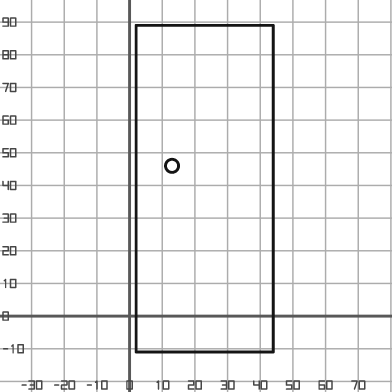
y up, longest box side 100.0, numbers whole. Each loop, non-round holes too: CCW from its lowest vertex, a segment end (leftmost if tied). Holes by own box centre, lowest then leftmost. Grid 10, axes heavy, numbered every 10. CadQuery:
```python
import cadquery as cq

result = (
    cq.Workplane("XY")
    .moveTo(2.0, -11.0)
    .lineTo(44.0, -11.0)
    .lineTo(44.0, 89.0)
    .lineTo(2.0, 89.0)
    .close()
    .moveTo(13.0, 46.0)
    .circle(2.0)
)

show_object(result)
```